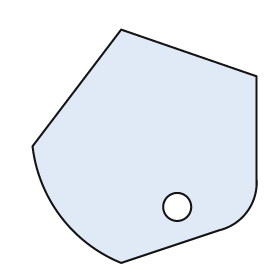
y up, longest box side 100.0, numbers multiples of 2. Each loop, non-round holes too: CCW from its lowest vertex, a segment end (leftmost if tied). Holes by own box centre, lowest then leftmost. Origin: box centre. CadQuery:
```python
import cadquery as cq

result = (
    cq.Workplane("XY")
    .moveTo(-10.0, -50.0)
    .lineTo(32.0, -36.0)
    .threePointArc((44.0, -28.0), (48.0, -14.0))
    .lineTo(48.0, 30.0)
    .lineTo(-10.0, 50.0)
    .lineTo(-48.0, 0.0)
    .threePointArc((-36.0, -30.0), (-10.0, -50.0))
    .close()
    .moveTo(14.0, -26.0)
    .circle(6.0)
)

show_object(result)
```